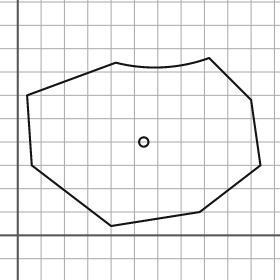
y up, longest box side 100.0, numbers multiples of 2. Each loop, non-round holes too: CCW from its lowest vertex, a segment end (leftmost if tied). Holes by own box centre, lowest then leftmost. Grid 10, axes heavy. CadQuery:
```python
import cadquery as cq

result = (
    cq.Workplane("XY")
    .moveTo(40.0, 4.0)
    .lineTo(78.0, 10.0)
    .lineTo(104.0, 30.0)
    .lineTo(100.0, 58.0)
    .lineTo(82.0, 76.0)
    .threePointArc((62.0, 72.0), (42.0, 74.0))
    .lineTo(4.0, 60.0)
    .lineTo(6.0, 30.0)
    .close()
    .moveTo(54.0, 40.0)
    .circle(2.0)
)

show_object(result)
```